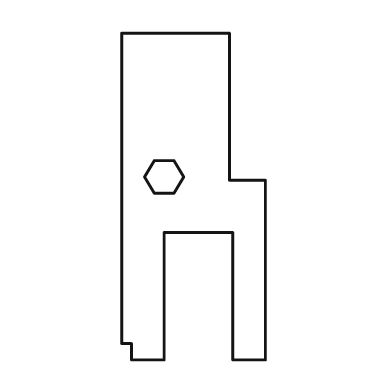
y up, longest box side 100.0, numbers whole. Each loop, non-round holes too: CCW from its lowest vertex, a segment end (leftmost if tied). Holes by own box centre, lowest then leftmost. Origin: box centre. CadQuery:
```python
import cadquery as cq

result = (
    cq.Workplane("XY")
    .moveTo(-19.0, -50.0)
    .lineTo(-9.0, -50.0)
    .lineTo(-9.0, -11.0)
    .lineTo(12.0, -11.0)
    .lineTo(12.0, -50.0)
    .lineTo(22.0, -50.0)
    .lineTo(22.0, 5.0)
    .lineTo(11.0, 5.0)
    .lineTo(11.0, 50.0)
    .lineTo(-22.0, 50.0)
    .lineTo(-22.0, -45.0)
    .lineTo(-19.0, -45.0)
    .close()
    .moveTo(-12.0, 1.0)
    .lineTo(-6.0, 1.0)
    .lineTo(-3.0, 6.0)
    .lineTo(-6.0, 11.0)
    .lineTo(-12.0, 11.0)
    .lineTo(-15.0, 6.0)
    .close()
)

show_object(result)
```